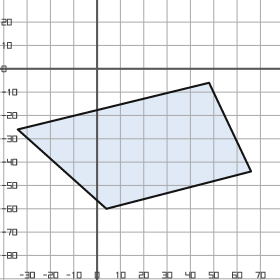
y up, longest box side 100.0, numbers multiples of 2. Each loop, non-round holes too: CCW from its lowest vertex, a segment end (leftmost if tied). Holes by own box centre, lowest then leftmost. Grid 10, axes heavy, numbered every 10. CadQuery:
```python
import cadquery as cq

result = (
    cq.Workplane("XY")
    .moveTo(4.0, -60.0)
    .lineTo(66.0, -44.0)
    .lineTo(48.0, -6.0)
    .lineTo(-34.0, -26.0)
    .close()
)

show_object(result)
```